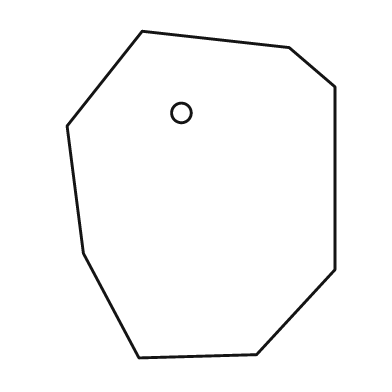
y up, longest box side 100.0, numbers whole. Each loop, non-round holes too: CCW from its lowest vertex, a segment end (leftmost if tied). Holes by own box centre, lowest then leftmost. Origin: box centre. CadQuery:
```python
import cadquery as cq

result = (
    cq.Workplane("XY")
    .moveTo(-19.0, -50.0)
    .lineTo(17.0, -49.0)
    .lineTo(41.0, -23.0)
    .lineTo(41.0, 33.0)
    .lineTo(27.0, 45.0)
    .lineTo(-18.0, 50.0)
    .lineTo(-41.0, 21.0)
    .lineTo(-36.0, -18.0)
    .close()
    .moveTo(-6.0, 25.0)
    .circle(3.0)
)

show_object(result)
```